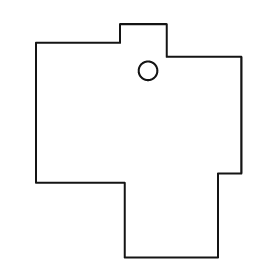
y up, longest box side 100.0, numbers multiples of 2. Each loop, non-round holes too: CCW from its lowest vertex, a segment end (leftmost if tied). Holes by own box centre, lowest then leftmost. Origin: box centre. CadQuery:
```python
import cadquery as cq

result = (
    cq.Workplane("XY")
    .moveTo(-6.0, -50.0)
    .lineTo(34.0, -50.0)
    .lineTo(34.0, -14.0)
    .lineTo(44.0, -14.0)
    .lineTo(44.0, 36.0)
    .lineTo(12.0, 36.0)
    .lineTo(12.0, 50.0)
    .lineTo(-8.0, 50.0)
    .lineTo(-8.0, 42.0)
    .lineTo(-44.0, 42.0)
    .lineTo(-44.0, -18.0)
    .lineTo(-6.0, -18.0)
    .close()
    .moveTo(4.0, 30.0)
    .circle(4.0)
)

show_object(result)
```